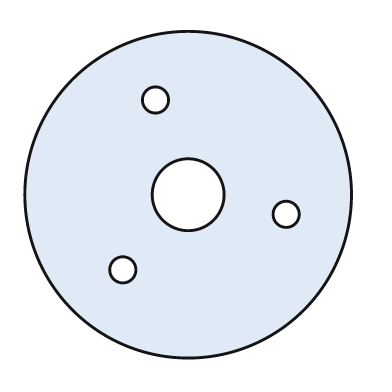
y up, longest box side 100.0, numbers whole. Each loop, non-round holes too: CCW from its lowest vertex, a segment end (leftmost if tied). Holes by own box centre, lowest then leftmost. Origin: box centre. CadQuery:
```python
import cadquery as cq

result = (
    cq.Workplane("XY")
    .moveTo(0.0, 0.0)
    .circle(50.0)
    .moveTo(-20.0, -23.0)
    .circle(4.0)
    .moveTo(30.0, -6.0)
    .circle(4.0)
    .moveTo(0.0, 0.0)
    .circle(11.0)
    .moveTo(-10.0, 29.0)
    .circle(4.0)
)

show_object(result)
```